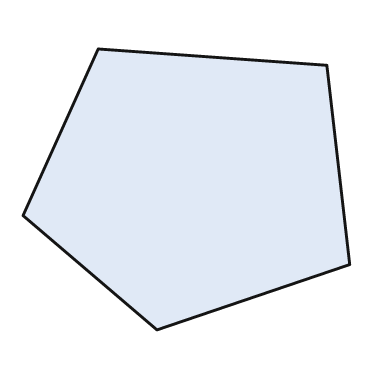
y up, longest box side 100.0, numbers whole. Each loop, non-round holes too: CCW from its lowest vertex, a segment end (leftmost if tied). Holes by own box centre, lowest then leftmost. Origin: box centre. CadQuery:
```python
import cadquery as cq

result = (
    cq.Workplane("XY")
    .moveTo(-9.0, -43.0)
    .lineTo(50.0, -23.0)
    .lineTo(43.0, 38.0)
    .lineTo(-27.0, 43.0)
    .lineTo(-50.0, -8.0)
    .close()
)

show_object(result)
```